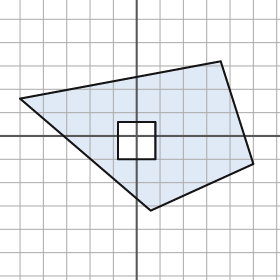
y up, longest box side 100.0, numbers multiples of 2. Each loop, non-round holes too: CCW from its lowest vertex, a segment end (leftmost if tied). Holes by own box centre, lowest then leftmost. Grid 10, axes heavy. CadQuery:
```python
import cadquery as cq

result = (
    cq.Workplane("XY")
    .moveTo(6.0, -32.0)
    .lineTo(50.0, -12.0)
    .lineTo(36.0, 32.0)
    .lineTo(-50.0, 16.0)
    .close()
    .moveTo(-8.0, -10.0)
    .lineTo(8.0, -10.0)
    .lineTo(8.0, 6.0)
    .lineTo(-8.0, 6.0)
    .close()
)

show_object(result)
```